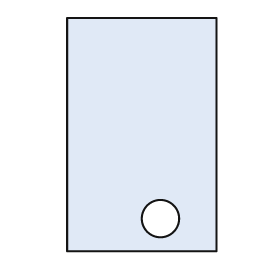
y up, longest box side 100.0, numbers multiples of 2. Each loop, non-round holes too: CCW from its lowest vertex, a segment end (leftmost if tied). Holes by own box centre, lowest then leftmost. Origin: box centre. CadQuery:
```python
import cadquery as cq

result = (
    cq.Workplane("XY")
    .moveTo(-32.0, -50.0)
    .lineTo(32.0, -50.0)
    .lineTo(32.0, 50.0)
    .lineTo(-32.0, 50.0)
    .close()
    .moveTo(8.0, -36.0)
    .circle(8.0)
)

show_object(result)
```